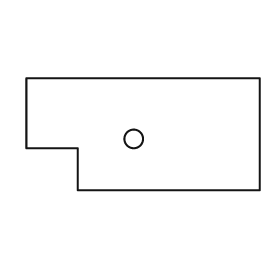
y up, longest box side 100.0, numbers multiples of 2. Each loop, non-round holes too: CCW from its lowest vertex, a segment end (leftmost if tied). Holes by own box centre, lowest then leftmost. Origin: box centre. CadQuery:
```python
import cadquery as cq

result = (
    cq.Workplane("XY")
    .moveTo(-28.0, -24.0)
    .lineTo(50.0, -24.0)
    .lineTo(50.0, 24.0)
    .lineTo(-50.0, 24.0)
    .lineTo(-50.0, -6.0)
    .lineTo(-28.0, -6.0)
    .close()
    .moveTo(-4.0, -2.0)
    .circle(4.0)
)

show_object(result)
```